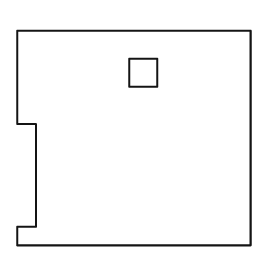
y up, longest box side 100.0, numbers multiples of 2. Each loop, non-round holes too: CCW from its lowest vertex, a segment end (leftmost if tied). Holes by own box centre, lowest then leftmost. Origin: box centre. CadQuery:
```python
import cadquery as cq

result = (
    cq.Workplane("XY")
    .moveTo(-50.0, -46.0)
    .lineTo(50.0, -46.0)
    .lineTo(50.0, 46.0)
    .lineTo(-50.0, 46.0)
    .lineTo(-50.0, 6.0)
    .lineTo(-42.0, 6.0)
    .lineTo(-42.0, -38.0)
    .lineTo(-50.0, -38.0)
    .close()
    .moveTo(-2.0, 22.0)
    .lineTo(10.0, 22.0)
    .lineTo(10.0, 34.0)
    .lineTo(-2.0, 34.0)
    .close()
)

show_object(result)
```